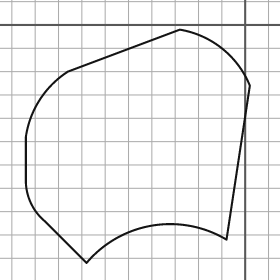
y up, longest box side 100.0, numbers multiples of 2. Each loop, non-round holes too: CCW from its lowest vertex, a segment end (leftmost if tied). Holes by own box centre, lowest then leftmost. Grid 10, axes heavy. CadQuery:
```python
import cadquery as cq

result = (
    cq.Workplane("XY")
    .moveTo(-68.0, -102.0)
    .threePointArc((-40.0, -86.0), (-8.0, -92.0))
    .lineTo(2.0, -26.0)
    .threePointArc((-10.0, -10.0), (-28.0, -2.0))
    .lineTo(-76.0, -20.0)
    .threePointArc((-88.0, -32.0), (-94.0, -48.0))
    .lineTo(-94.0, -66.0)
    .threePointArc((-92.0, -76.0), (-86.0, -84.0))
    .close()
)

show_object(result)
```